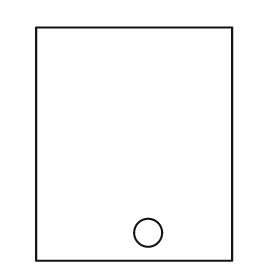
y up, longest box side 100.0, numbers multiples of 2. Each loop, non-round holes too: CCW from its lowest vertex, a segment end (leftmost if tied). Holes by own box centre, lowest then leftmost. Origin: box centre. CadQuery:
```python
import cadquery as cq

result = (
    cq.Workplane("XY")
    .moveTo(-42.0, -50.0)
    .lineTo(42.0, -50.0)
    .lineTo(42.0, 50.0)
    .lineTo(-42.0, 50.0)
    .close()
    .moveTo(6.0, -38.0)
    .circle(6.0)
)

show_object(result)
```